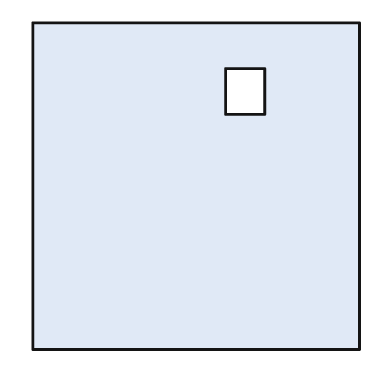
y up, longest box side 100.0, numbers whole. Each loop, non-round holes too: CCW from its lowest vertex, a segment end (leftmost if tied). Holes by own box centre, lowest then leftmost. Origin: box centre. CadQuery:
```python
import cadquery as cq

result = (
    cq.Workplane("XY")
    .moveTo(-50.0, -50.0)
    .lineTo(50.0, -50.0)
    .lineTo(50.0, 50.0)
    .lineTo(-50.0, 50.0)
    .close()
    .moveTo(9.0, 22.0)
    .lineTo(21.0, 22.0)
    .lineTo(21.0, 36.0)
    .lineTo(9.0, 36.0)
    .close()
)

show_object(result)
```